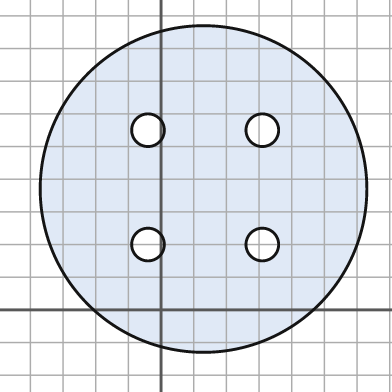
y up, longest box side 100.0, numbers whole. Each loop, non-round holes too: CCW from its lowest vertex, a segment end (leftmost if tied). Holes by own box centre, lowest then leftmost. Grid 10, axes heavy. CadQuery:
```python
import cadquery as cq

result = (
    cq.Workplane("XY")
    .moveTo(13.0, 37.0)
    .circle(50.0)
    .moveTo(-4.0, 20.0)
    .circle(5.0)
    .moveTo(31.0, 20.0)
    .circle(5.0)
    .moveTo(-4.0, 55.0)
    .circle(5.0)
    .moveTo(31.0, 55.0)
    .circle(5.0)
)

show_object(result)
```